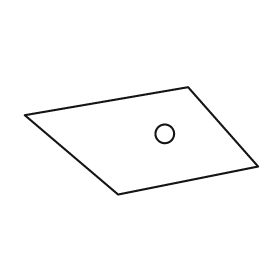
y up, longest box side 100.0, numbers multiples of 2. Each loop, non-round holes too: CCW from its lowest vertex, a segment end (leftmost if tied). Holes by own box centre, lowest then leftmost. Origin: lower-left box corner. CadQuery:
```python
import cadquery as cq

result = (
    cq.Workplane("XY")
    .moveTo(40.0, 0.0)
    .lineTo(100.0, 12.0)
    .lineTo(70.0, 46.0)
    .lineTo(0.0, 34.0)
    .close()
    .moveTo(60.0, 26.0)
    .circle(4.0)
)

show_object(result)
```